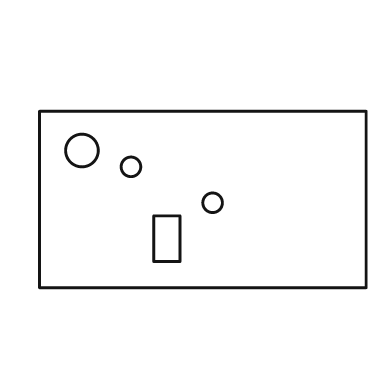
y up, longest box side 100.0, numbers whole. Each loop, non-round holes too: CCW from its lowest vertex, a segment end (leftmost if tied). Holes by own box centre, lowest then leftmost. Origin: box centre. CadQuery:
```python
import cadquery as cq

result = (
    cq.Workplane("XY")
    .moveTo(-50.0, -27.0)
    .lineTo(50.0, -27.0)
    .lineTo(50.0, 27.0)
    .lineTo(-50.0, 27.0)
    .close()
    .moveTo(-15.0, -19.0)
    .lineTo(-7.0, -19.0)
    .lineTo(-7.0, -5.0)
    .lineTo(-15.0, -5.0)
    .close()
    .moveTo(3.0, -1.0)
    .circle(3.0)
    .moveTo(-22.0, 10.0)
    .circle(3.0)
    .moveTo(-37.0, 15.0)
    .circle(5.0)
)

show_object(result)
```